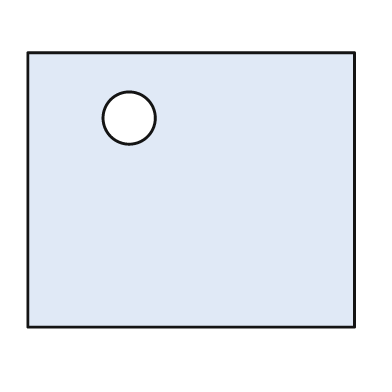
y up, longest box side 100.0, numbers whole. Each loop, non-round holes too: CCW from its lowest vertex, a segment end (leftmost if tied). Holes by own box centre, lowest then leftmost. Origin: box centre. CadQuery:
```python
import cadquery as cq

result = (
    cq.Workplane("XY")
    .moveTo(-50.0, -42.0)
    .lineTo(50.0, -42.0)
    .lineTo(50.0, 42.0)
    .lineTo(-50.0, 42.0)
    .close()
    .moveTo(-19.0, 22.0)
    .circle(8.0)
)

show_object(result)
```